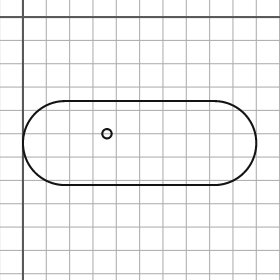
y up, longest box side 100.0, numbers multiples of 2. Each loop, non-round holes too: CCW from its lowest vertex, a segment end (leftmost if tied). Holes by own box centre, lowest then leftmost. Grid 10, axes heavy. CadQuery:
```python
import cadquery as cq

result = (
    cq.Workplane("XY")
    .moveTo(18.0, -72.0)
    .lineTo(82.0, -72.0)
    .threePointArc((100.0, -54.0), (82.0, -36.0))
    .lineTo(18.0, -36.0)
    .threePointArc((0.0, -54.0), (18.0, -72.0))
    .close()
    .moveTo(36.0, -50.0)
    .circle(2.0)
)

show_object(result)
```